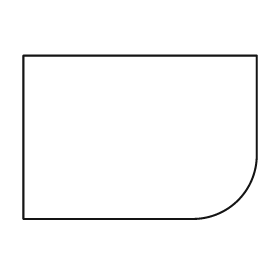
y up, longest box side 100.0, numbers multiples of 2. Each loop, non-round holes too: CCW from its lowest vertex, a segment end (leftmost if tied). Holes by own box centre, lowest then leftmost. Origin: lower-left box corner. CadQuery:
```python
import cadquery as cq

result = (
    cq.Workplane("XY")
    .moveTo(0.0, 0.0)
    .lineTo(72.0, 0.0)
    .threePointArc((92.0, 8.0), (100.0, 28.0))
    .lineTo(100.0, 70.0)
    .lineTo(0.0, 70.0)
    .close()
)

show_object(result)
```